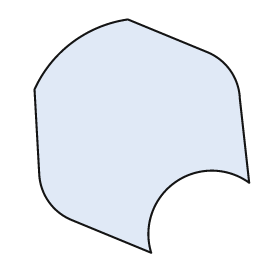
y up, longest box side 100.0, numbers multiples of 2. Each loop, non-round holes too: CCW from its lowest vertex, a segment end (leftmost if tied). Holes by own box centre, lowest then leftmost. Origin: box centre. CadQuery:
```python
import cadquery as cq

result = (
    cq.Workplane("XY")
    .moveTo(4.0, -50.0)
    .threePointArc((14.0, -20.0), (46.0, -20.0))
    .lineTo(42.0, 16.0)
    .threePointArc((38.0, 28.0), (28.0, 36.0))
    .lineTo(-6.0, 50.0)
    .threePointArc((-30.0, 40.0), (-46.0, 20.0))
    .lineTo(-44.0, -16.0)
    .threePointArc((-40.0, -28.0), (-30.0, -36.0))
    .close()
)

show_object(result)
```